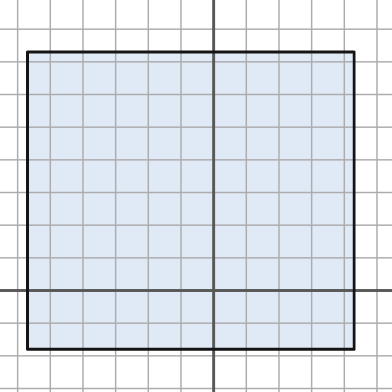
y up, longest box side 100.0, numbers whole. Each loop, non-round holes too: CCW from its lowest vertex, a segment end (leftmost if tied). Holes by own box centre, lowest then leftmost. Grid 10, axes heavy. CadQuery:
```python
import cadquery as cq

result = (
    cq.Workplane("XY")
    .moveTo(-57.0, -18.0)
    .lineTo(43.0, -18.0)
    .lineTo(43.0, 73.0)
    .lineTo(-57.0, 73.0)
    .close()
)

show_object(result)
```